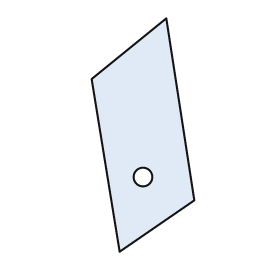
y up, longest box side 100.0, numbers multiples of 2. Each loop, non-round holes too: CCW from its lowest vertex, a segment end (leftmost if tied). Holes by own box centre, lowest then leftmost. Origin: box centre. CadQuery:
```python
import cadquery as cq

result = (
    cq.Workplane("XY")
    .moveTo(-10.0, -50.0)
    .lineTo(22.0, -28.0)
    .lineTo(10.0, 50.0)
    .lineTo(-22.0, 24.0)
    .close()
    .moveTo(0.0, -18.0)
    .circle(4.0)
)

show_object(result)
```